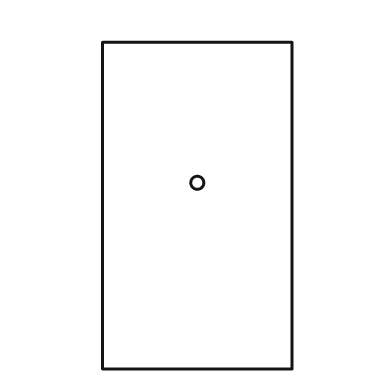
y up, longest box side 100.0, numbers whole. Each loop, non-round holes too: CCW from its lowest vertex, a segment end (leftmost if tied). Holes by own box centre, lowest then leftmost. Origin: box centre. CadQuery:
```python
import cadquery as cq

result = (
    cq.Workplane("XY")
    .moveTo(-29.0, -50.0)
    .lineTo(29.0, -50.0)
    .lineTo(29.0, 50.0)
    .lineTo(-29.0, 50.0)
    .close()
    .moveTo(0.0, 7.0)
    .circle(2.0)
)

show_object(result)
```